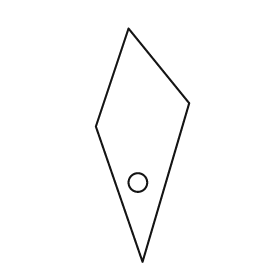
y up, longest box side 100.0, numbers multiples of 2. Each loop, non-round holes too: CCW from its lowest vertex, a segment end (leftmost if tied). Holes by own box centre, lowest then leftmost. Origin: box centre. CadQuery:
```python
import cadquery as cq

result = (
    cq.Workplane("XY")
    .moveTo(0.0, -50.0)
    .lineTo(20.0, 18.0)
    .lineTo(-6.0, 50.0)
    .lineTo(-20.0, 8.0)
    .close()
    .moveTo(-2.0, -16.0)
    .circle(4.0)
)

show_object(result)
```